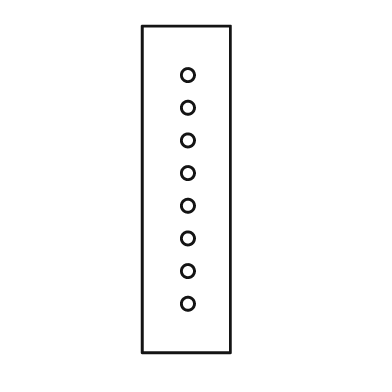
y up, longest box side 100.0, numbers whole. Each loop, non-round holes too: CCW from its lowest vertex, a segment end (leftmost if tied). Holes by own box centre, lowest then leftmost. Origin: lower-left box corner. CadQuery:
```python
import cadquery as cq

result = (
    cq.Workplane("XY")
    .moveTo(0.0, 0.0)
    .lineTo(27.0, 0.0)
    .lineTo(27.0, 100.0)
    .lineTo(0.0, 100.0)
    .close()
    .moveTo(14.0, 15.0)
    .circle(2.0)
    .moveTo(14.0, 25.0)
    .circle(2.0)
    .moveTo(14.0, 35.0)
    .circle(2.0)
    .moveTo(14.0, 45.0)
    .circle(2.0)
    .moveTo(14.0, 55.0)
    .circle(2.0)
    .moveTo(14.0, 65.0)
    .circle(2.0)
    .moveTo(14.0, 75.0)
    .circle(2.0)
    .moveTo(14.0, 85.0)
    .circle(2.0)
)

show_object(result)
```